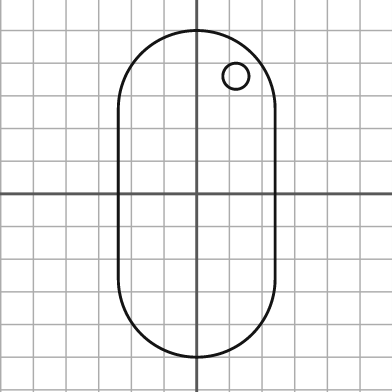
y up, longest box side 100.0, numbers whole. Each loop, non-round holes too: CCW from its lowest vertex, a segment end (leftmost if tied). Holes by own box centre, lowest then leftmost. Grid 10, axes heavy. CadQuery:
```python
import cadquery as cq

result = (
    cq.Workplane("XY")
    .moveTo(-24.0, -26.0)
    .threePointArc((0.0, -50.0), (24.0, -26.0))
    .lineTo(24.0, 26.0)
    .threePointArc((0.0, 50.0), (-24.0, 26.0))
    .close()
    .moveTo(12.0, 36.0)
    .circle(4.0)
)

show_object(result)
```